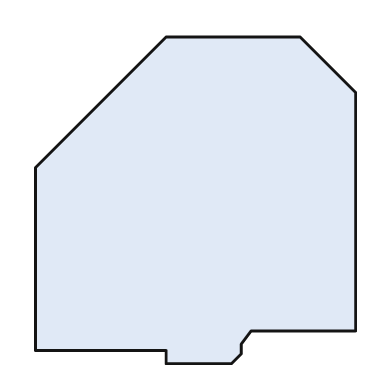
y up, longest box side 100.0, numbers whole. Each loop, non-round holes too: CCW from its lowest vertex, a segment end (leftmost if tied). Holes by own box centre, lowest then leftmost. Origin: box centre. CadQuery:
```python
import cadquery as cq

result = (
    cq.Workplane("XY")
    .moveTo(-9.0, -50.0)
    .lineTo(11.0, -50.0)
    .lineTo(14.0, -47.0)
    .lineTo(14.0, -44.0)
    .lineTo(17.0, -40.0)
    .lineTo(49.0, -40.0)
    .lineTo(49.0, 33.0)
    .lineTo(32.0, 50.0)
    .lineTo(-9.0, 50.0)
    .lineTo(-49.0, 10.0)
    .lineTo(-49.0, -46.0)
    .lineTo(-9.0, -46.0)
    .close()
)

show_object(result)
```